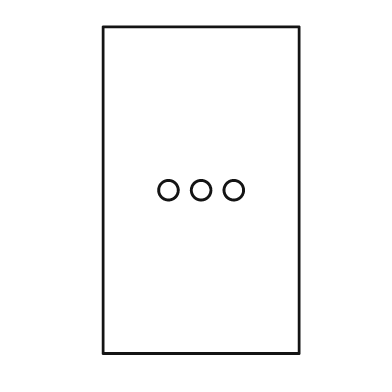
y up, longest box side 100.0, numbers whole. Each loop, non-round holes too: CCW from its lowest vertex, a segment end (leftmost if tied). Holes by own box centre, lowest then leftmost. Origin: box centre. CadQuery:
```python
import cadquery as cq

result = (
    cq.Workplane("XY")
    .moveTo(-30.0, -50.0)
    .lineTo(30.0, -50.0)
    .lineTo(30.0, 50.0)
    .lineTo(-30.0, 50.0)
    .close()
    .moveTo(-10.0, 0.0)
    .circle(3.0)
    .moveTo(0.0, 0.0)
    .circle(3.0)
    .moveTo(10.0, 0.0)
    .circle(3.0)
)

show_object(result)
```